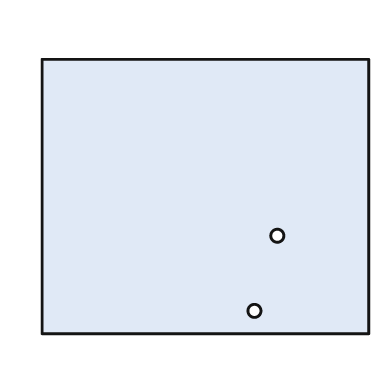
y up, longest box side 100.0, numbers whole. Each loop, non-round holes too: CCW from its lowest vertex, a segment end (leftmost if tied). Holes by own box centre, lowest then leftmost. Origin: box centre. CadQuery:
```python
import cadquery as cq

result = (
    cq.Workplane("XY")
    .moveTo(-50.0, -42.0)
    .lineTo(50.0, -42.0)
    .lineTo(50.0, 42.0)
    .lineTo(-50.0, 42.0)
    .close()
    .moveTo(15.0, -35.0)
    .circle(2.0)
    .moveTo(22.0, -12.0)
    .circle(2.0)
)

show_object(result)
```